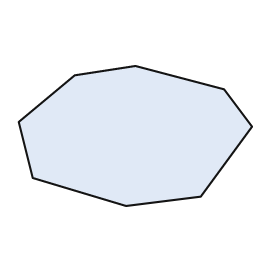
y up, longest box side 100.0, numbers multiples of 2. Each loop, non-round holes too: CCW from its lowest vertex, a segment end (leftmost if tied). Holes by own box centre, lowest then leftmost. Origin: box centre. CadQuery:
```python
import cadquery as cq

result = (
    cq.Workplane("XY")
    .moveTo(-4.0, -30.0)
    .lineTo(28.0, -26.0)
    .lineTo(50.0, 4.0)
    .lineTo(38.0, 20.0)
    .lineTo(0.0, 30.0)
    .lineTo(-26.0, 26.0)
    .lineTo(-50.0, 6.0)
    .lineTo(-44.0, -18.0)
    .close()
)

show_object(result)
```